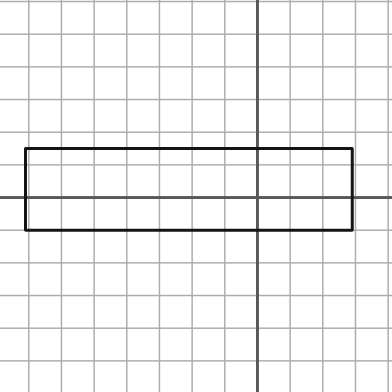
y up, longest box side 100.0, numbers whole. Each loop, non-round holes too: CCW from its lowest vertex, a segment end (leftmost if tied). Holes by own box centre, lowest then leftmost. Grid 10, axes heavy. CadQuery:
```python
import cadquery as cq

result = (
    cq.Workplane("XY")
    .moveTo(-71.0, -10.0)
    .lineTo(29.0, -10.0)
    .lineTo(29.0, 15.0)
    .lineTo(-71.0, 15.0)
    .close()
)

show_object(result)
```